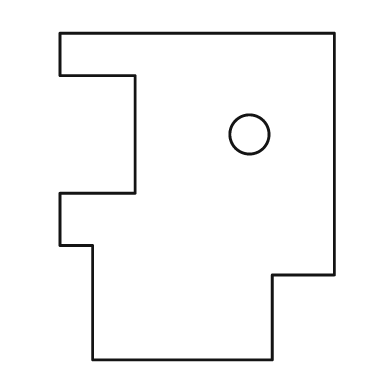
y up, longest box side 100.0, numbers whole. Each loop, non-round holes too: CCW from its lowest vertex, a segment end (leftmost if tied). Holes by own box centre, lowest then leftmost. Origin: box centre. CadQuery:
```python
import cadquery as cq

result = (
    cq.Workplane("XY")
    .moveTo(-32.0, -50.0)
    .lineTo(23.0, -50.0)
    .lineTo(23.0, -24.0)
    .lineTo(42.0, -24.0)
    .lineTo(42.0, 50.0)
    .lineTo(-42.0, 50.0)
    .lineTo(-42.0, 37.0)
    .lineTo(-19.0, 37.0)
    .lineTo(-19.0, 1.0)
    .lineTo(-42.0, 1.0)
    .lineTo(-42.0, -15.0)
    .lineTo(-32.0, -15.0)
    .close()
    .moveTo(16.0, 19.0)
    .circle(6.0)
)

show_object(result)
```